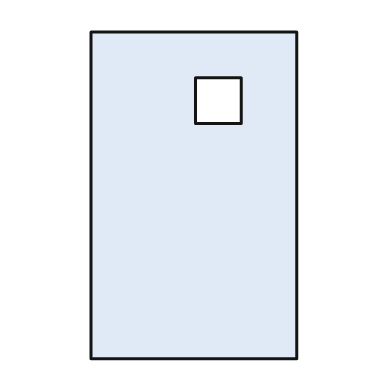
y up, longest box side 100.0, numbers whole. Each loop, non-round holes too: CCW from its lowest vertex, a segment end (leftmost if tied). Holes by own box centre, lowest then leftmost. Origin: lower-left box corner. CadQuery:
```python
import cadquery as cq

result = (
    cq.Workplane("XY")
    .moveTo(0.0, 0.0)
    .lineTo(63.0, 0.0)
    .lineTo(63.0, 100.0)
    .lineTo(0.0, 100.0)
    .close()
    .moveTo(32.0, 72.0)
    .lineTo(46.0, 72.0)
    .lineTo(46.0, 86.0)
    .lineTo(32.0, 86.0)
    .close()
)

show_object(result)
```